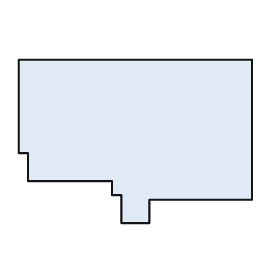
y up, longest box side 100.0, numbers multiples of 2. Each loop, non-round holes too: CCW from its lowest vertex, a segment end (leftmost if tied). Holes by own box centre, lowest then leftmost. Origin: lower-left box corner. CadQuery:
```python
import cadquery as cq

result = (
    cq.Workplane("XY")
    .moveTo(44.0, 0.0)
    .lineTo(56.0, 0.0)
    .lineTo(56.0, 10.0)
    .lineTo(100.0, 10.0)
    .lineTo(100.0, 70.0)
    .lineTo(0.0, 70.0)
    .lineTo(0.0, 30.0)
    .lineTo(4.0, 30.0)
    .lineTo(4.0, 18.0)
    .lineTo(40.0, 18.0)
    .lineTo(40.0, 12.0)
    .lineTo(44.0, 12.0)
    .close()
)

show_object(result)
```